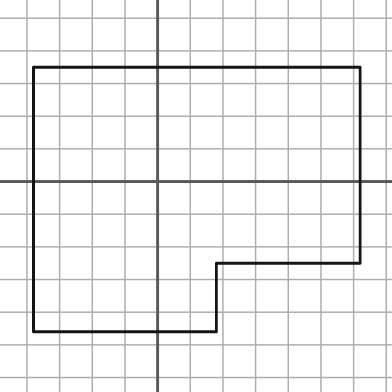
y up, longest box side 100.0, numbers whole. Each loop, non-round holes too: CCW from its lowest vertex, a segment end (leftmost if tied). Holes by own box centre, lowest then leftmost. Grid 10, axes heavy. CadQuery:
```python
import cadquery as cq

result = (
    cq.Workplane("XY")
    .moveTo(-38.0, -46.0)
    .lineTo(18.0, -46.0)
    .lineTo(18.0, -25.0)
    .lineTo(62.0, -25.0)
    .lineTo(62.0, 35.0)
    .lineTo(-38.0, 35.0)
    .close()
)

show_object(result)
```